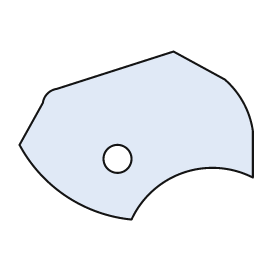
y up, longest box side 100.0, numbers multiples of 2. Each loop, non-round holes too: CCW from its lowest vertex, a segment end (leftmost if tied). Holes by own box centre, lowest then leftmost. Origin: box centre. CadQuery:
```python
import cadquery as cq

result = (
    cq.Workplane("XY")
    .moveTo(-2.0, -36.0)
    .threePointArc((20.0, -16.0), (50.0, -18.0))
    .lineTo(50.0, 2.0)
    .threePointArc((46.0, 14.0), (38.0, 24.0))
    .lineTo(16.0, 36.0)
    .lineTo(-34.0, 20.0)
    .threePointArc((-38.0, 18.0), (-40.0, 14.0))
    .lineTo(-50.0, -4.0)
    .threePointArc((-30.0, -26.0), (-2.0, -36.0))
    .close()
    .moveTo(-8.0, -10.0)
    .circle(6.0)
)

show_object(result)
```